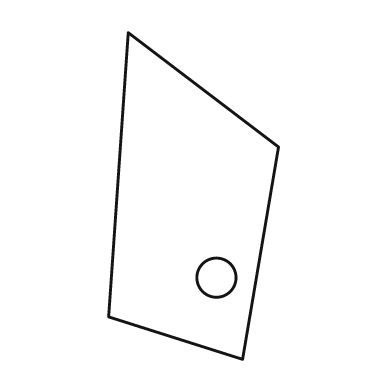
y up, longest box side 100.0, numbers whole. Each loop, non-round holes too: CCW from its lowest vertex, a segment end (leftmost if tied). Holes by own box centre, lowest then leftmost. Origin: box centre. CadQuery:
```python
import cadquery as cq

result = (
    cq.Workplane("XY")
    .moveTo(15.0, -50.0)
    .lineTo(26.0, 15.0)
    .lineTo(-20.0, 50.0)
    .lineTo(-26.0, -37.0)
    .close()
    .moveTo(7.0, -25.0)
    .circle(6.0)
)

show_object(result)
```